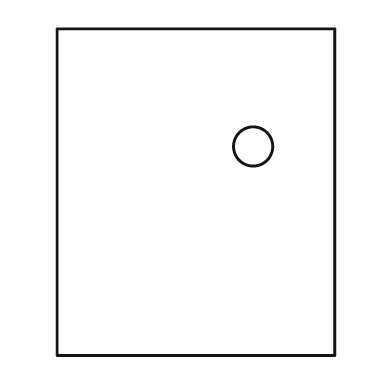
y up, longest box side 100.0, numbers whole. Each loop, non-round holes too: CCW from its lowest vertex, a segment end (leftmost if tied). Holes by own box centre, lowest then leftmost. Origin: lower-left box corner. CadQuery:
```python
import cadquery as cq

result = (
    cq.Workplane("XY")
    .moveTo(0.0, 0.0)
    .lineTo(85.0, 0.0)
    .lineTo(85.0, 100.0)
    .lineTo(0.0, 100.0)
    .close()
    .moveTo(60.0, 64.0)
    .circle(6.0)
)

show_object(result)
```